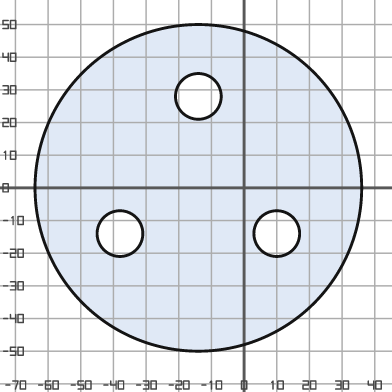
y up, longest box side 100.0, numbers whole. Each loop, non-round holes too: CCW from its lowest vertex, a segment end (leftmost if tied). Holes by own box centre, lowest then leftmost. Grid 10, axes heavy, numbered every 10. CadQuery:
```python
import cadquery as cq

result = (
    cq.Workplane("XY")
    .moveTo(-14.0, 0.0)
    .circle(50.0)
    .moveTo(-38.0, -14.0)
    .circle(7.0)
    .moveTo(10.0, -14.0)
    .circle(7.0)
    .moveTo(-14.0, 28.0)
    .circle(7.0)
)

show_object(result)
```